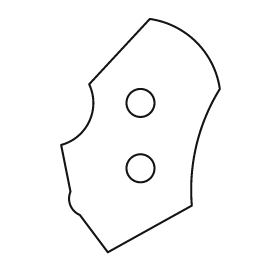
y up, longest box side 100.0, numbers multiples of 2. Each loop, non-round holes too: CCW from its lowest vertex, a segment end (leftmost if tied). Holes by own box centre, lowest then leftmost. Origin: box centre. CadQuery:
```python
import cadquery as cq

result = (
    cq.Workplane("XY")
    .moveTo(-14.0, -50.0)
    .lineTo(22.0, -30.0)
    .threePointArc((24.0, -4.0), (34.0, 20.0))
    .threePointArc((24.0, 40.0), (4.0, 50.0))
    .lineTo(-22.0, 22.0)
    .threePointArc((-22.0, 6.0), (-34.0, -4.0))
    .lineTo(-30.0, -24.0)
    .threePointArc((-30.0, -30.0), (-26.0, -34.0))
    .close()
    .moveTo(0.0, -14.0)
    .circle(6.0)
    .moveTo(0.0, 14.0)
    .circle(6.0)
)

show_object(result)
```